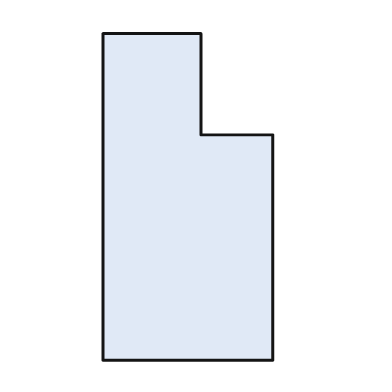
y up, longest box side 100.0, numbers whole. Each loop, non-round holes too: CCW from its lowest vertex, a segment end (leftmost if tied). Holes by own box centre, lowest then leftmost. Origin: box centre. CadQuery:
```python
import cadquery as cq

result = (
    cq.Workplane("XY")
    .moveTo(-26.0, -50.0)
    .lineTo(26.0, -50.0)
    .lineTo(26.0, 19.0)
    .lineTo(4.0, 19.0)
    .lineTo(4.0, 50.0)
    .lineTo(-26.0, 50.0)
    .close()
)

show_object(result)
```